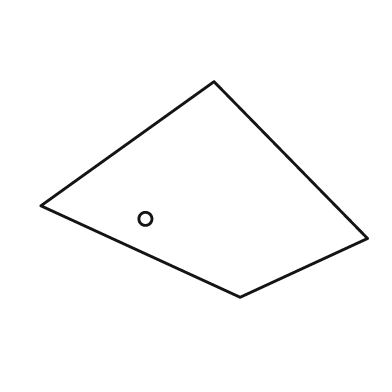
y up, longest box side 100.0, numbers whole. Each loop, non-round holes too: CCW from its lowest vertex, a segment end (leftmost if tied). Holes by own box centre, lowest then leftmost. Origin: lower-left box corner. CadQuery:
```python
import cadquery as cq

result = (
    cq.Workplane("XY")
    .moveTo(61.0, 0.0)
    .lineTo(100.0, 18.0)
    .lineTo(53.0, 66.0)
    .lineTo(0.0, 28.0)
    .close()
    .moveTo(32.0, 24.0)
    .circle(2.0)
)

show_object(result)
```